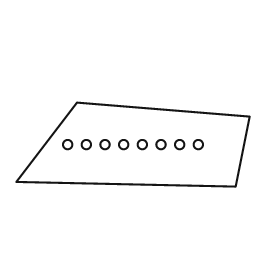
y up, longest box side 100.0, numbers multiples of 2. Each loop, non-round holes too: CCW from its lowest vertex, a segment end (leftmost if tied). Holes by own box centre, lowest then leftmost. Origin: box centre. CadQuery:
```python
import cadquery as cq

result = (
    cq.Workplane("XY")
    .moveTo(44.0, -18.0)
    .lineTo(50.0, 12.0)
    .lineTo(-24.0, 18.0)
    .lineTo(-50.0, -16.0)
    .close()
    .moveTo(-28.0, 0.0)
    .circle(2.0)
    .moveTo(-20.0, 0.0)
    .circle(2.0)
    .moveTo(-12.0, 0.0)
    .circle(2.0)
    .moveTo(-4.0, 0.0)
    .circle(2.0)
    .moveTo(4.0, 0.0)
    .circle(2.0)
    .moveTo(12.0, 0.0)
    .circle(2.0)
    .moveTo(20.0, 0.0)
    .circle(2.0)
    .moveTo(28.0, 0.0)
    .circle(2.0)
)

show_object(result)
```